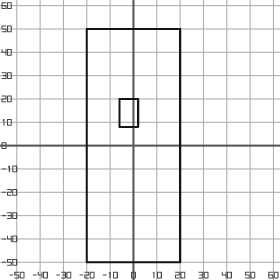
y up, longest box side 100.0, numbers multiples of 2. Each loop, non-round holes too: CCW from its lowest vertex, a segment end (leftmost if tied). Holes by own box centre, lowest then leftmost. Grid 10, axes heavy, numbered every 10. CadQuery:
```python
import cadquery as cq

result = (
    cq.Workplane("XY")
    .moveTo(-20.0, -50.0)
    .lineTo(20.0, -50.0)
    .lineTo(20.0, 50.0)
    .lineTo(-20.0, 50.0)
    .close()
    .moveTo(-6.0, 8.0)
    .lineTo(2.0, 8.0)
    .lineTo(2.0, 20.0)
    .lineTo(-6.0, 20.0)
    .close()
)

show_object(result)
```